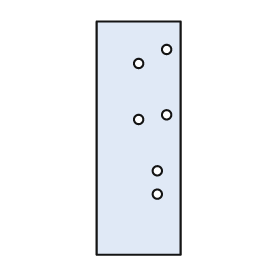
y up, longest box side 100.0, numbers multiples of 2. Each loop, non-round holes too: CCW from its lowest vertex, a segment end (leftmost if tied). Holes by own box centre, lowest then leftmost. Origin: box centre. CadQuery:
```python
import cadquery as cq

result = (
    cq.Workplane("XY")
    .moveTo(-18.0, -50.0)
    .lineTo(18.0, -50.0)
    .lineTo(18.0, 50.0)
    .lineTo(-18.0, 50.0)
    .close()
    .moveTo(8.0, -24.0)
    .circle(2.0)
    .moveTo(8.0, -14.0)
    .circle(2.0)
    .moveTo(0.0, 8.0)
    .circle(2.0)
    .moveTo(12.0, 10.0)
    .circle(2.0)
    .moveTo(0.0, 32.0)
    .circle(2.0)
    .moveTo(12.0, 38.0)
    .circle(2.0)
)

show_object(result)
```